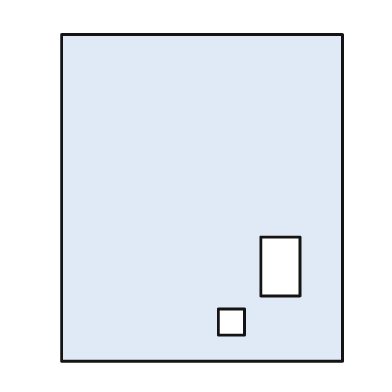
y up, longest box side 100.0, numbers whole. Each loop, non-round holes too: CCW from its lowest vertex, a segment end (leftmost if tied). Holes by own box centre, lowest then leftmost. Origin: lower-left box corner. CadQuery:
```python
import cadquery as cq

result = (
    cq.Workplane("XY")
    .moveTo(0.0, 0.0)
    .lineTo(86.0, 0.0)
    .lineTo(86.0, 100.0)
    .lineTo(0.0, 100.0)
    .close()
    .moveTo(48.0, 8.0)
    .lineTo(56.0, 8.0)
    .lineTo(56.0, 16.0)
    .lineTo(48.0, 16.0)
    .close()
    .moveTo(61.0, 20.0)
    .lineTo(73.0, 20.0)
    .lineTo(73.0, 38.0)
    .lineTo(61.0, 38.0)
    .close()
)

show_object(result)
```